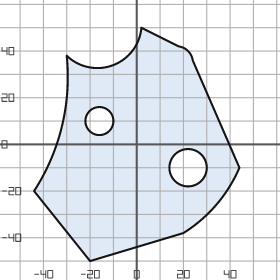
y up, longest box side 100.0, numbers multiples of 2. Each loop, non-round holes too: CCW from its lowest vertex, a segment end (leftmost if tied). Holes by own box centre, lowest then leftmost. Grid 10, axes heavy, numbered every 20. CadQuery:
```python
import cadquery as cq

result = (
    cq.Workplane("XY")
    .moveTo(-20.0, -50.0)
    .lineTo(20.0, -38.0)
    .threePointArc((34.0, -26.0), (44.0, -10.0))
    .lineTo(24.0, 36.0)
    .threePointArc((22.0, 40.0), (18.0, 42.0))
    .lineTo(2.0, 50.0)
    .threePointArc((-10.0, 34.0), (-30.0, 38.0))
    .threePointArc((-32.0, 8.0), (-44.0, -20.0))
    .close()
    .moveTo(22.0, -10.0)
    .circle(8.0)
    .moveTo(-16.0, 10.0)
    .circle(6.0)
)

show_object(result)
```